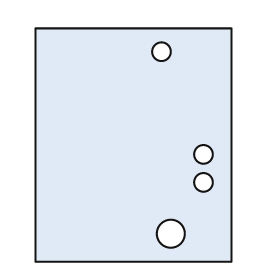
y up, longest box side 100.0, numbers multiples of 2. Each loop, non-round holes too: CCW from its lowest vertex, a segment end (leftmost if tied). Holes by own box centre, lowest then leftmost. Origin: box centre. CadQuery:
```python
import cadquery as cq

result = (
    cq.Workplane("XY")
    .moveTo(-42.0, -50.0)
    .lineTo(42.0, -50.0)
    .lineTo(42.0, 50.0)
    .lineTo(-42.0, 50.0)
    .close()
    .moveTo(16.0, -38.0)
    .circle(6.0)
    .moveTo(30.0, -16.0)
    .circle(4.0)
    .moveTo(30.0, -4.0)
    .circle(4.0)
    .moveTo(12.0, 40.0)
    .circle(4.0)
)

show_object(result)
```